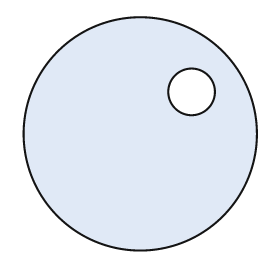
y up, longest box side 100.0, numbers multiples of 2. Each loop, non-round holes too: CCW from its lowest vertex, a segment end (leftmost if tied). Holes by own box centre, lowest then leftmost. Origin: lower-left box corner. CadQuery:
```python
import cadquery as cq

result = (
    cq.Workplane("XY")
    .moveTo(50.0, 50.0)
    .circle(50.0)
    .moveTo(72.0, 68.0)
    .circle(10.0)
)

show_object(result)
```